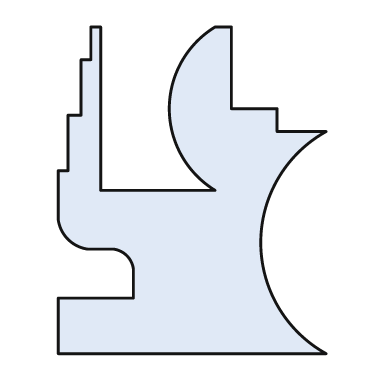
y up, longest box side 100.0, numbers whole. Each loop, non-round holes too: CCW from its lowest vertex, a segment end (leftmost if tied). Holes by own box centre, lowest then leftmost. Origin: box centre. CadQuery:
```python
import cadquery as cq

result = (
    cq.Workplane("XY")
    .moveTo(-41.0, -50.0)
    .lineTo(41.0, -50.0)
    .threePointArc((21.0, -16.0), (41.0, 18.0))
    .lineTo(26.0, 18.0)
    .lineTo(26.0, 25.0)
    .lineTo(12.0, 25.0)
    .lineTo(12.0, 50.0)
    .lineTo(7.0, 50.0)
    .threePointArc((-7.0, 25.0), (7.0, 0.0))
    .lineTo(-28.0, 0.0)
    .lineTo(-28.0, 50.0)
    .lineTo(-31.0, 50.0)
    .lineTo(-31.0, 40.0)
    .lineTo(-34.0, 40.0)
    .lineTo(-34.0, 23.0)
    .lineTo(-38.0, 23.0)
    .lineTo(-38.0, 6.0)
    .lineTo(-41.0, 6.0)
    .lineTo(-41.0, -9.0)
    .threePointArc((-38.0, -15.0), (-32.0, -18.0))
    .lineTo(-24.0, -18.0)
    .threePointArc((-20.0, -20.0), (-18.0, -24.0))
    .lineTo(-18.0, -33.0)
    .lineTo(-41.0, -33.0)
    .close()
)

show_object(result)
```